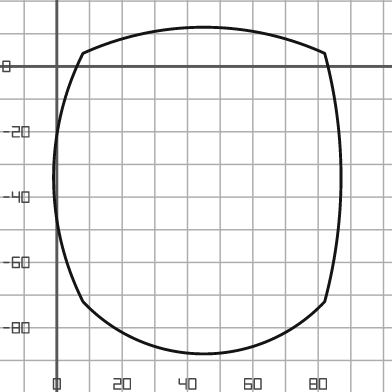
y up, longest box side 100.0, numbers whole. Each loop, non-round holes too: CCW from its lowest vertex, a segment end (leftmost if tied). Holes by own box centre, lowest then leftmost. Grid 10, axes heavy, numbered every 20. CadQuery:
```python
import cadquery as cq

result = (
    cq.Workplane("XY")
    .moveTo(8.0, -72.0)
    .threePointArc((45.0, -88.0), (82.0, -72.0))
    .threePointArc((87.0, -34.0), (82.0, 4.0))
    .threePointArc((45.0, 12.0), (8.0, 4.0))
    .threePointArc((-1.0, -34.0), (8.0, -72.0))
    .close()
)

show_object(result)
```